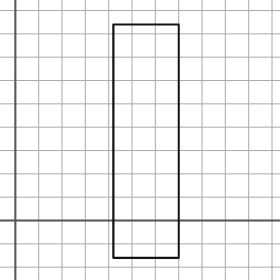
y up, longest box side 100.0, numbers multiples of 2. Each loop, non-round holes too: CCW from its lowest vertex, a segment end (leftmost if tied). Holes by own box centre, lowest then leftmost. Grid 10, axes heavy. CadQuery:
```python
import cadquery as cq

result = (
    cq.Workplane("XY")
    .moveTo(42.0, -16.0)
    .lineTo(70.0, -16.0)
    .lineTo(70.0, 84.0)
    .lineTo(42.0, 84.0)
    .close()
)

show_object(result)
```